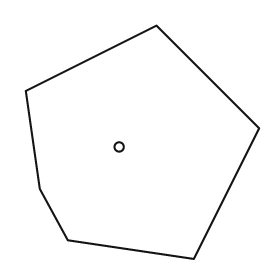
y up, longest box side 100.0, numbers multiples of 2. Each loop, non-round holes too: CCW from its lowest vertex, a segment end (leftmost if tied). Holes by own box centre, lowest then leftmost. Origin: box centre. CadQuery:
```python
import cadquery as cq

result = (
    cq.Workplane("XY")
    .moveTo(22.0, -50.0)
    .lineTo(50.0, 6.0)
    .lineTo(6.0, 50.0)
    .lineTo(-50.0, 22.0)
    .lineTo(-44.0, -20.0)
    .lineTo(-32.0, -42.0)
    .close()
    .moveTo(-10.0, -2.0)
    .circle(2.0)
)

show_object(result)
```